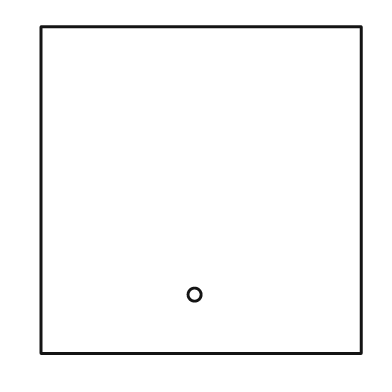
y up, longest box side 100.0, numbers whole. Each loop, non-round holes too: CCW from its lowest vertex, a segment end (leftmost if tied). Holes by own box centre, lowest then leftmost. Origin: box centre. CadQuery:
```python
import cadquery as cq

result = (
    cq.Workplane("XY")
    .moveTo(-49.0, -50.0)
    .lineTo(49.0, -50.0)
    .lineTo(49.0, 50.0)
    .lineTo(-49.0, 50.0)
    .close()
    .moveTo(-2.0, -32.0)
    .circle(2.0)
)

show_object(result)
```